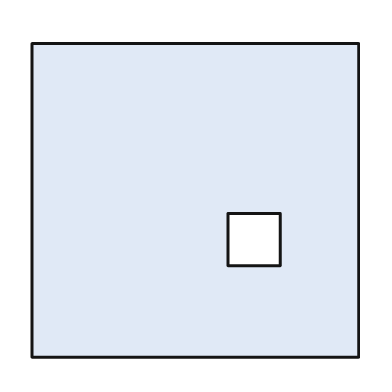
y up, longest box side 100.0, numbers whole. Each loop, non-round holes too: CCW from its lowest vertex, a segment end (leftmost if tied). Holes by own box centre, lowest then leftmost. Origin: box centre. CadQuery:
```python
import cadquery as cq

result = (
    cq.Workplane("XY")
    .moveTo(-50.0, -48.0)
    .lineTo(50.0, -48.0)
    .lineTo(50.0, 48.0)
    .lineTo(-50.0, 48.0)
    .close()
    .moveTo(10.0, -20.0)
    .lineTo(26.0, -20.0)
    .lineTo(26.0, -4.0)
    .lineTo(10.0, -4.0)
    .close()
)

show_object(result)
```